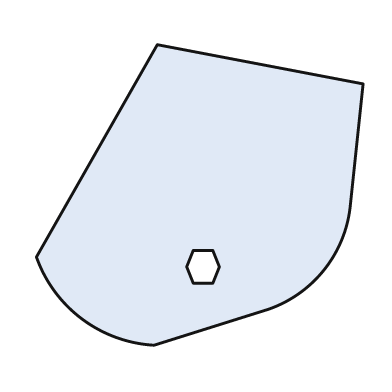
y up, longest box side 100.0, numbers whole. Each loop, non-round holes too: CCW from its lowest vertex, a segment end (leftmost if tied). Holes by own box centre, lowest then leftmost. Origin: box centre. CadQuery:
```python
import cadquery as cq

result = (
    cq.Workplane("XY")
    .moveTo(-14.0, -46.0)
    .lineTo(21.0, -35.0)
    .threePointArc((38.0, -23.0), (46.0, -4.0))
    .lineTo(50.0, 34.0)
    .lineTo(-13.0, 46.0)
    .lineTo(-50.0, -19.0)
    .threePointArc((-36.0, -38.0), (-14.0, -46.0))
    .close()
    .moveTo(-2.0, -27.0)
    .lineTo(4.0, -27.0)
    .lineTo(6.0, -22.0)
    .lineTo(4.0, -17.0)
    .lineTo(-2.0, -17.0)
    .lineTo(-4.0, -22.0)
    .close()
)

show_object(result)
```